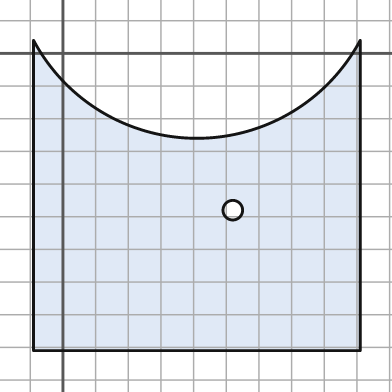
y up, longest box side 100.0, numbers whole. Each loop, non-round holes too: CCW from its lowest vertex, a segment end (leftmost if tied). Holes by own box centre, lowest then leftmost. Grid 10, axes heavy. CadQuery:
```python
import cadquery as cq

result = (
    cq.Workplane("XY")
    .moveTo(-9.0, -91.0)
    .lineTo(91.0, -91.0)
    .lineTo(91.0, 4.0)
    .threePointArc((41.0, -26.0), (-9.0, 4.0))
    .close()
    .moveTo(52.0, -48.0)
    .circle(3.0)
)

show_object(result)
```